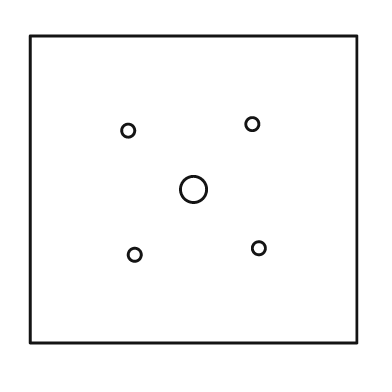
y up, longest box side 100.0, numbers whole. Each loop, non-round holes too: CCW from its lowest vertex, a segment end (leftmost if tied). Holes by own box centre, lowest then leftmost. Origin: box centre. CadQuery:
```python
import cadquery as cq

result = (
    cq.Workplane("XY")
    .moveTo(-50.0, -47.0)
    .lineTo(50.0, -47.0)
    .lineTo(50.0, 47.0)
    .lineTo(-50.0, 47.0)
    .close()
    .moveTo(-18.0, -20.0)
    .circle(2.0)
    .moveTo(20.0, -18.0)
    .circle(2.0)
    .moveTo(0.0, 0.0)
    .circle(4.0)
    .moveTo(-20.0, 18.0)
    .circle(2.0)
    .moveTo(18.0, 20.0)
    .circle(2.0)
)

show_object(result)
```